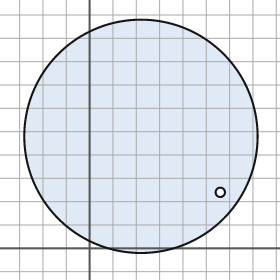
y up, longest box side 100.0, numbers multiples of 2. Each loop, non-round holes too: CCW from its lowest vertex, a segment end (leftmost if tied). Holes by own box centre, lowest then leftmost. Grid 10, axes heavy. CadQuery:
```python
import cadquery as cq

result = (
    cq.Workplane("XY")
    .moveTo(22.0, 48.0)
    .circle(50.0)
    .moveTo(56.0, 24.0)
    .circle(2.0)
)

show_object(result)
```